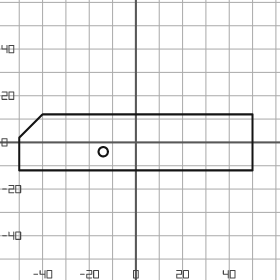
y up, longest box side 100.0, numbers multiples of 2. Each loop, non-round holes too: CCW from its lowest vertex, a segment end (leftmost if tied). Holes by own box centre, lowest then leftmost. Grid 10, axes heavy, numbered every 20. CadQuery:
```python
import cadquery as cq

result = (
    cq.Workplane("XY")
    .moveTo(-50.0, -12.0)
    .lineTo(50.0, -12.0)
    .lineTo(50.0, 12.0)
    .lineTo(-40.0, 12.0)
    .lineTo(-50.0, 2.0)
    .close()
    .moveTo(-14.0, -4.0)
    .circle(2.0)
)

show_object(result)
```